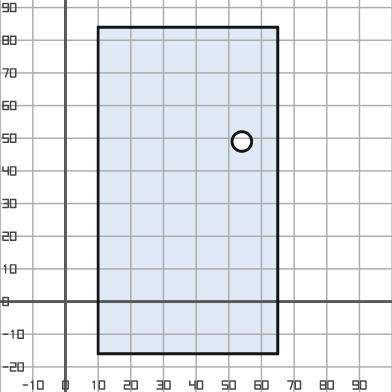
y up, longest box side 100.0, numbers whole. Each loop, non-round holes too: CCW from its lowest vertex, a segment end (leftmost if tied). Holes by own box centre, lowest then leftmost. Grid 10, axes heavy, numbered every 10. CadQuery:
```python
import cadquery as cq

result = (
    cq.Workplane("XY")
    .moveTo(10.0, -16.0)
    .lineTo(65.0, -16.0)
    .lineTo(65.0, 84.0)
    .lineTo(10.0, 84.0)
    .close()
    .moveTo(54.0, 49.0)
    .circle(3.0)
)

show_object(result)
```